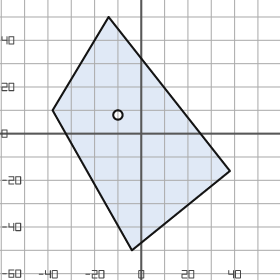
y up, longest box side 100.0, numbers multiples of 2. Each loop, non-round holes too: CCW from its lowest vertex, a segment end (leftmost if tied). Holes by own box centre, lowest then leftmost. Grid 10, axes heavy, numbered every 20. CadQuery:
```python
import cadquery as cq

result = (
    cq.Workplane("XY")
    .moveTo(-4.0, -50.0)
    .lineTo(38.0, -16.0)
    .lineTo(-14.0, 50.0)
    .lineTo(-38.0, 10.0)
    .close()
    .moveTo(-10.0, 8.0)
    .circle(2.0)
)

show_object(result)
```